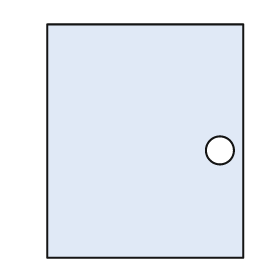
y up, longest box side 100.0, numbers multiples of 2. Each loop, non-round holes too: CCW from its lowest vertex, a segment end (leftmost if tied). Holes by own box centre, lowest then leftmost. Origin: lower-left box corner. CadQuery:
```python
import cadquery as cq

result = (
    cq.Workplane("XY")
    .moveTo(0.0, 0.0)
    .lineTo(84.0, 0.0)
    .lineTo(84.0, 100.0)
    .lineTo(0.0, 100.0)
    .close()
    .moveTo(74.0, 46.0)
    .circle(6.0)
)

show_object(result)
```